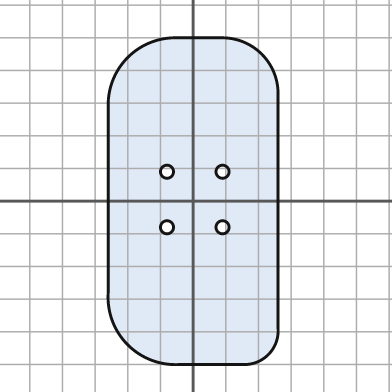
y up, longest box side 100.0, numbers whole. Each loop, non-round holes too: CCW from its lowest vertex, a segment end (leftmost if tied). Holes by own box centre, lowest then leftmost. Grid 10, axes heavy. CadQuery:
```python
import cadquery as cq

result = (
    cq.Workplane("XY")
    .moveTo(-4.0, -50.0)
    .lineTo(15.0, -50.0)
    .threePointArc((23.0, -47.0), (26.0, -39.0))
    .lineTo(26.0, 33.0)
    .threePointArc((21.0, 45.0), (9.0, 50.0))
    .lineTo(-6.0, 50.0)
    .threePointArc((-20.0, 44.0), (-26.0, 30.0))
    .lineTo(-26.0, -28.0)
    .threePointArc((-20.0, -44.0), (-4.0, -50.0))
    .close()
    .moveTo(-8.0, -8.0)
    .circle(2.0)
    .moveTo(9.0, -8.0)
    .circle(2.0)
    .moveTo(-8.0, 9.0)
    .circle(2.0)
    .moveTo(9.0, 9.0)
    .circle(2.0)
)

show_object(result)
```